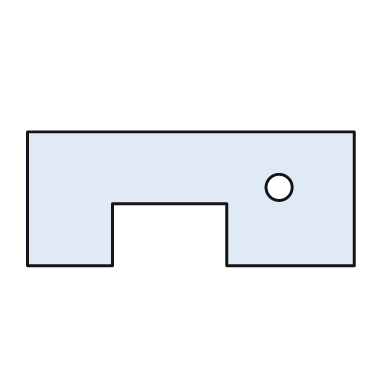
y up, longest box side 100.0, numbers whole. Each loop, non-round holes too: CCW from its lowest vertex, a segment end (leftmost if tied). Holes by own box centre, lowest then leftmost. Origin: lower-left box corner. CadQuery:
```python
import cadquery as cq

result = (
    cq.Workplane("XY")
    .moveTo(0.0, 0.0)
    .lineTo(26.0, 0.0)
    .lineTo(26.0, 19.0)
    .lineTo(61.0, 19.0)
    .lineTo(61.0, 0.0)
    .lineTo(100.0, 0.0)
    .lineTo(100.0, 41.0)
    .lineTo(0.0, 41.0)
    .close()
    .moveTo(77.0, 24.0)
    .circle(4.0)
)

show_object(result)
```